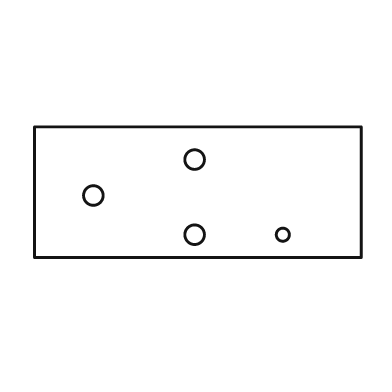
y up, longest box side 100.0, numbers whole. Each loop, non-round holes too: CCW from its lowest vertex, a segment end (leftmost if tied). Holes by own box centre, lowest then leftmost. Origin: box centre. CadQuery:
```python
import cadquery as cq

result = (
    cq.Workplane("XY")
    .moveTo(-50.0, -20.0)
    .lineTo(50.0, -20.0)
    .lineTo(50.0, 20.0)
    .lineTo(-50.0, 20.0)
    .close()
    .moveTo(-1.0, -13.0)
    .circle(3.0)
    .moveTo(26.0, -13.0)
    .circle(2.0)
    .moveTo(-32.0, -1.0)
    .circle(3.0)
    .moveTo(-1.0, 10.0)
    .circle(3.0)
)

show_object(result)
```